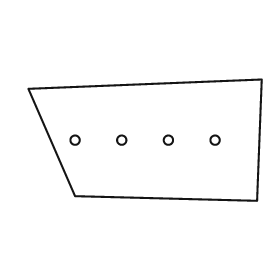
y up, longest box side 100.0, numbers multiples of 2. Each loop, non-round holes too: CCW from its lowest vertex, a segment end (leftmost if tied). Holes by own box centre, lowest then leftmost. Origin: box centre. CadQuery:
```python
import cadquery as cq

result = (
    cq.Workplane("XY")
    .moveTo(48.0, -26.0)
    .lineTo(50.0, 26.0)
    .lineTo(-50.0, 22.0)
    .lineTo(-30.0, -24.0)
    .close()
    .moveTo(-30.0, 0.0)
    .circle(2.0)
    .moveTo(-10.0, 0.0)
    .circle(2.0)
    .moveTo(10.0, 0.0)
    .circle(2.0)
    .moveTo(30.0, 0.0)
    .circle(2.0)
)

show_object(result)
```